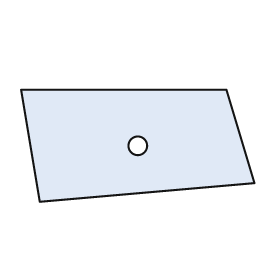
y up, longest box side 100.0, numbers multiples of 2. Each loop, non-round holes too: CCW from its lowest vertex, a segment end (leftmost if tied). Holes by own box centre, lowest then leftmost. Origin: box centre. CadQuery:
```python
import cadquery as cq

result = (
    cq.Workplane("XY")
    .moveTo(-42.0, -24.0)
    .lineTo(50.0, -16.0)
    .lineTo(38.0, 24.0)
    .lineTo(-50.0, 24.0)
    .close()
    .moveTo(0.0, 0.0)
    .circle(4.0)
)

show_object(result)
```